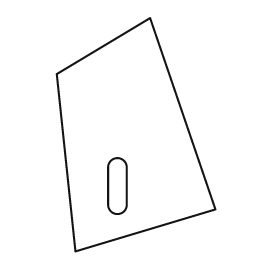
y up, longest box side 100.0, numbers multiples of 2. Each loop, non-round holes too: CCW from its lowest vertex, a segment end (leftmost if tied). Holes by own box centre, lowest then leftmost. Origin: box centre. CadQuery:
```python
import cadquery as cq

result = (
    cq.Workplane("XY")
    .moveTo(-26.0, -50.0)
    .lineTo(34.0, -32.0)
    .lineTo(6.0, 50.0)
    .lineTo(-34.0, 26.0)
    .close()
    .moveTo(-12.0, -30.0)
    .threePointArc((-8.0, -34.0), (-4.0, -30.0))
    .lineTo(-4.0, -14.0)
    .threePointArc((-8.0, -10.0), (-12.0, -14.0))
    .close()
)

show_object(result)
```